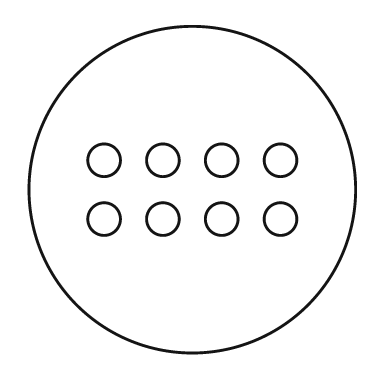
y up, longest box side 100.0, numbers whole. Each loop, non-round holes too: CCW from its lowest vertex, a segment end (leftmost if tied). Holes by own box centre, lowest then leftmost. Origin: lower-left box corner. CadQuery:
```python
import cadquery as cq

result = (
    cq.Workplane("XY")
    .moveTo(50.0, 50.0)
    .circle(50.0)
    .moveTo(23.0, 41.0)
    .circle(5.0)
    .moveTo(41.0, 41.0)
    .circle(5.0)
    .moveTo(59.0, 41.0)
    .circle(5.0)
    .moveTo(77.0, 41.0)
    .circle(5.0)
    .moveTo(23.0, 59.0)
    .circle(5.0)
    .moveTo(41.0, 59.0)
    .circle(5.0)
    .moveTo(59.0, 59.0)
    .circle(5.0)
    .moveTo(77.0, 59.0)
    .circle(5.0)
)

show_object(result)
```